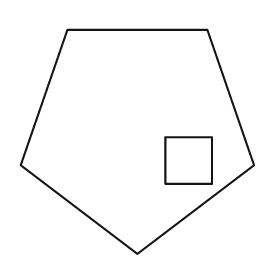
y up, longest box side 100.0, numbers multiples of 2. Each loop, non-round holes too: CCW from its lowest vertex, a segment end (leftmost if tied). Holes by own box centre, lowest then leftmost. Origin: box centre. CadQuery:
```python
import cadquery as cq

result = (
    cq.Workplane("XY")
    .moveTo(0.0, -48.0)
    .lineTo(50.0, -10.0)
    .lineTo(30.0, 48.0)
    .lineTo(-30.0, 48.0)
    .lineTo(-50.0, -10.0)
    .close()
    .moveTo(12.0, -18.0)
    .lineTo(32.0, -18.0)
    .lineTo(32.0, 2.0)
    .lineTo(12.0, 2.0)
    .close()
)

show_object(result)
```